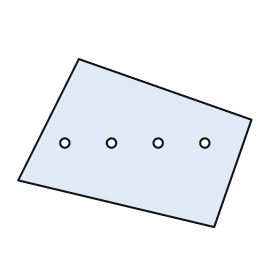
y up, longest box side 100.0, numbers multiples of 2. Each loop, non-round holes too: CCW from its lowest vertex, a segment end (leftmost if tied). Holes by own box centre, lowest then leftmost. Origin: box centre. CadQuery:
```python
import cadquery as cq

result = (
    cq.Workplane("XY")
    .moveTo(34.0, -36.0)
    .lineTo(50.0, 10.0)
    .lineTo(-24.0, 36.0)
    .lineTo(-50.0, -16.0)
    .close()
    .moveTo(-30.0, 0.0)
    .circle(2.0)
    .moveTo(-10.0, 0.0)
    .circle(2.0)
    .moveTo(10.0, 0.0)
    .circle(2.0)
    .moveTo(30.0, 0.0)
    .circle(2.0)
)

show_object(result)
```